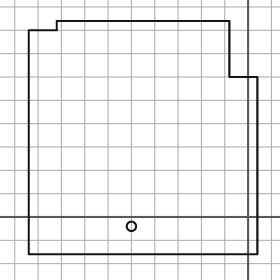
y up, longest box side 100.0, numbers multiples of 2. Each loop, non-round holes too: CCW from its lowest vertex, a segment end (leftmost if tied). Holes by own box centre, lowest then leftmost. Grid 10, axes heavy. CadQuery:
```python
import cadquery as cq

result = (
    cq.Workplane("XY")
    .moveTo(-94.0, -16.0)
    .lineTo(4.0, -16.0)
    .lineTo(4.0, 60.0)
    .lineTo(-8.0, 60.0)
    .lineTo(-8.0, 84.0)
    .lineTo(-82.0, 84.0)
    .lineTo(-82.0, 80.0)
    .lineTo(-94.0, 80.0)
    .close()
    .moveTo(-50.0, -4.0)
    .circle(2.0)
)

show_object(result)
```